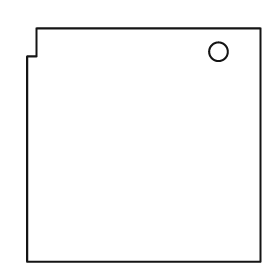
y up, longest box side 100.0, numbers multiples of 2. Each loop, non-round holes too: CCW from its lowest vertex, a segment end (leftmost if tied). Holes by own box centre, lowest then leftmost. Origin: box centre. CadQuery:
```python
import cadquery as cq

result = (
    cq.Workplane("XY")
    .moveTo(-50.0, -50.0)
    .lineTo(50.0, -50.0)
    .lineTo(50.0, 50.0)
    .lineTo(-46.0, 50.0)
    .lineTo(-46.0, 38.0)
    .lineTo(-50.0, 38.0)
    .close()
    .moveTo(32.0, 40.0)
    .circle(4.0)
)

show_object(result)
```